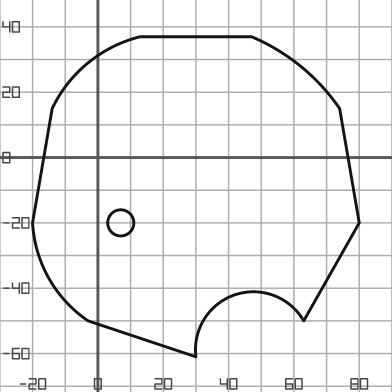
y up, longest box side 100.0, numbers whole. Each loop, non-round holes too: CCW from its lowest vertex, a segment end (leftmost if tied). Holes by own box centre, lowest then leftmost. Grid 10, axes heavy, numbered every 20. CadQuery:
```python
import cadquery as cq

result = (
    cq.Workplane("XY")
    .moveTo(30.0, -61.0)
    .threePointArc((42.0, -42.0), (63.0, -50.0))
    .lineTo(80.0, -20.0)
    .lineTo(74.0, 15.0)
    .threePointArc((62.0, 28.0), (47.0, 37.0))
    .lineTo(13.0, 37.0)
    .threePointArc((-3.0, 29.0), (-14.0, 15.0))
    .lineTo(-20.0, -20.0)
    .threePointArc((-15.0, -37.0), (-3.0, -50.0))
    .close()
    .moveTo(7.0, -20.0)
    .circle(4.0)
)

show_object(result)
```